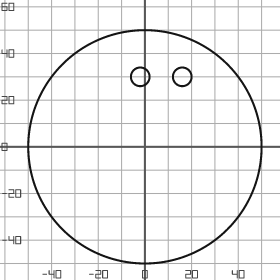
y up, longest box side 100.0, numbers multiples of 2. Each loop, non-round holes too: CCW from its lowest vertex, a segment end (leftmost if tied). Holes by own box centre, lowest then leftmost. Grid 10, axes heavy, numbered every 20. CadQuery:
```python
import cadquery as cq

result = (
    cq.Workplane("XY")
    .moveTo(0.0, 0.0)
    .circle(50.0)
    .moveTo(-2.0, 30.0)
    .circle(4.0)
    .moveTo(16.0, 30.0)
    .circle(4.0)
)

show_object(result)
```